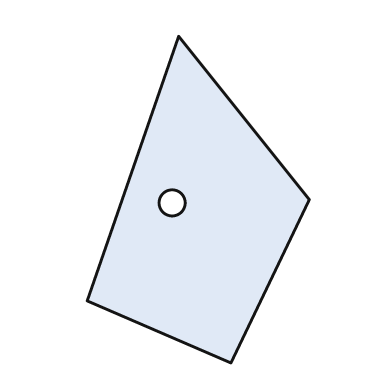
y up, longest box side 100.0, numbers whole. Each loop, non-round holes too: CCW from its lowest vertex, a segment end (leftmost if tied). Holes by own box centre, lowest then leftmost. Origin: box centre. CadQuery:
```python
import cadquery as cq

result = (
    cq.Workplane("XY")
    .moveTo(10.0, -50.0)
    .lineTo(34.0, 0.0)
    .lineTo(-6.0, 50.0)
    .lineTo(-34.0, -31.0)
    .close()
    .moveTo(-8.0, -1.0)
    .circle(4.0)
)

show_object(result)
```